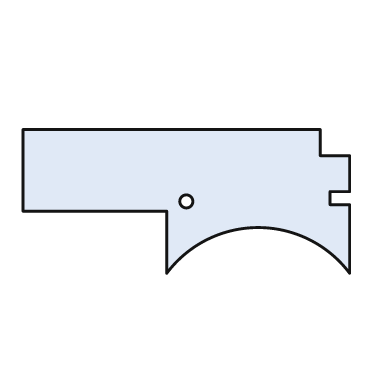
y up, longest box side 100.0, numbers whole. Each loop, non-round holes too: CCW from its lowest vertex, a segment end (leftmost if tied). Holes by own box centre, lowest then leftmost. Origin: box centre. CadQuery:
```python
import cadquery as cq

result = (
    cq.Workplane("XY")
    .moveTo(-6.0, -22.0)
    .threePointArc((22.0, -8.0), (50.0, -22.0))
    .lineTo(50.0, -1.0)
    .lineTo(44.0, -1.0)
    .lineTo(44.0, 3.0)
    .lineTo(50.0, 3.0)
    .lineTo(50.0, 14.0)
    .lineTo(41.0, 14.0)
    .lineTo(41.0, 22.0)
    .lineTo(-50.0, 22.0)
    .lineTo(-50.0, -3.0)
    .lineTo(-6.0, -3.0)
    .close()
    .moveTo(0.0, 0.0)
    .circle(2.0)
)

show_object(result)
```